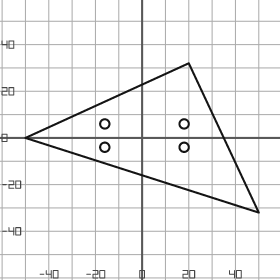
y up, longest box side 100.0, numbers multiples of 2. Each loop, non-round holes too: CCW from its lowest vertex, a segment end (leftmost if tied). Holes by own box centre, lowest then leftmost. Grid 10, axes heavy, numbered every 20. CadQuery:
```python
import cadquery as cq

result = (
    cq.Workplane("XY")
    .moveTo(50.0, -32.0)
    .lineTo(20.0, 32.0)
    .lineTo(-50.0, 0.0)
    .close()
    .moveTo(-16.0, -4.0)
    .circle(2.0)
    .moveTo(18.0, -4.0)
    .circle(2.0)
    .moveTo(-16.0, 6.0)
    .circle(2.0)
    .moveTo(18.0, 6.0)
    .circle(2.0)
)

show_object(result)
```